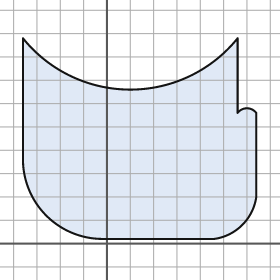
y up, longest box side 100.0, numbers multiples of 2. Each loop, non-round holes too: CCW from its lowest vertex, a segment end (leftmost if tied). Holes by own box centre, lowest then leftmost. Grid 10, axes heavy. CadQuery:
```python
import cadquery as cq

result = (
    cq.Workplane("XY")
    .moveTo(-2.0, 2.0)
    .lineTo(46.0, 2.0)
    .threePointArc((58.0, 8.0), (64.0, 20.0))
    .lineTo(64.0, 56.0)
    .threePointArc((60.0, 58.0), (56.0, 56.0))
    .lineTo(56.0, 88.0)
    .threePointArc((10.0, 66.0), (-36.0, 88.0))
    .lineTo(-36.0, 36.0)
    .threePointArc((-26.0, 12.0), (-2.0, 2.0))
    .close()
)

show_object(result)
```